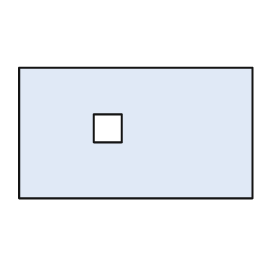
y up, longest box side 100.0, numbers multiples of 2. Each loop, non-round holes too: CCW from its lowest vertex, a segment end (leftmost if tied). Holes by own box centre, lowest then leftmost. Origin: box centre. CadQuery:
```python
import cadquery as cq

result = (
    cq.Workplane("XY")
    .moveTo(-50.0, -28.0)
    .lineTo(50.0, -28.0)
    .lineTo(50.0, 28.0)
    .lineTo(-50.0, 28.0)
    .close()
    .moveTo(-18.0, -4.0)
    .lineTo(-6.0, -4.0)
    .lineTo(-6.0, 8.0)
    .lineTo(-18.0, 8.0)
    .close()
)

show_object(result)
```